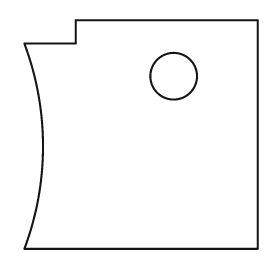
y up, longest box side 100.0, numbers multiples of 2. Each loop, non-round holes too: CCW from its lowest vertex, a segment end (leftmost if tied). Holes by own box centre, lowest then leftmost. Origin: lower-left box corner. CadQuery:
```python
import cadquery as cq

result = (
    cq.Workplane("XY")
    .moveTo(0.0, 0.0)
    .lineTo(100.0, 0.0)
    .lineTo(100.0, 98.0)
    .lineTo(22.0, 98.0)
    .lineTo(22.0, 88.0)
    .lineTo(0.0, 88.0)
    .threePointArc((8.0, 44.0), (0.0, 0.0))
    .close()
    .moveTo(64.0, 74.0)
    .circle(10.0)
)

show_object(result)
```